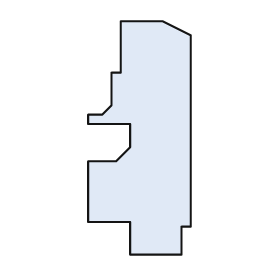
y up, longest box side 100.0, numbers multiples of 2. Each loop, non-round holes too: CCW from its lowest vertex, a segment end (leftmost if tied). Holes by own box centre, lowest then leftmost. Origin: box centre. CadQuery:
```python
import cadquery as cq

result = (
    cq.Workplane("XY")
    .moveTo(-4.0, -50.0)
    .lineTo(18.0, -50.0)
    .lineTo(18.0, -38.0)
    .lineTo(22.0, -38.0)
    .lineTo(22.0, 44.0)
    .lineTo(10.0, 50.0)
    .lineTo(-8.0, 50.0)
    .lineTo(-8.0, 28.0)
    .lineTo(-12.0, 28.0)
    .lineTo(-12.0, 14.0)
    .lineTo(-16.0, 10.0)
    .lineTo(-22.0, 10.0)
    .lineTo(-22.0, 6.0)
    .lineTo(-4.0, 6.0)
    .lineTo(-4.0, -4.0)
    .lineTo(-10.0, -10.0)
    .lineTo(-22.0, -10.0)
    .lineTo(-22.0, -36.0)
    .lineTo(-4.0, -36.0)
    .close()
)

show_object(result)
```